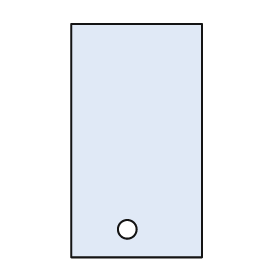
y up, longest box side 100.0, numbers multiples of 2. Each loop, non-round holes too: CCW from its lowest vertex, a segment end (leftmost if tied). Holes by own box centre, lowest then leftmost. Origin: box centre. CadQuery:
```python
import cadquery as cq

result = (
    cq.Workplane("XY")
    .moveTo(-28.0, -50.0)
    .lineTo(28.0, -50.0)
    .lineTo(28.0, 50.0)
    .lineTo(-28.0, 50.0)
    .close()
    .moveTo(-4.0, -38.0)
    .circle(4.0)
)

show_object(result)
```